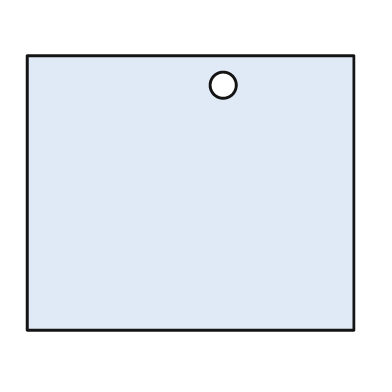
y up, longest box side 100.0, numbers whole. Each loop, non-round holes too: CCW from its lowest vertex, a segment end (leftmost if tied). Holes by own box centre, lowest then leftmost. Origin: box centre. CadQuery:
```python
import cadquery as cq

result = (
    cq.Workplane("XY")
    .moveTo(-50.0, -42.0)
    .lineTo(50.0, -42.0)
    .lineTo(50.0, 42.0)
    .lineTo(-50.0, 42.0)
    .close()
    .moveTo(10.0, 33.0)
    .circle(4.0)
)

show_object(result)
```